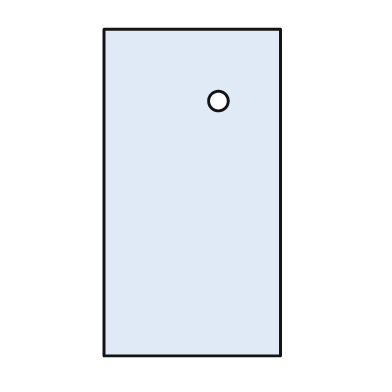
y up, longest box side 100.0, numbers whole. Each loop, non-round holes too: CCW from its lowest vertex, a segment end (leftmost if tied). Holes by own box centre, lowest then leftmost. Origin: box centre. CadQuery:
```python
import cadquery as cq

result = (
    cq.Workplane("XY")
    .moveTo(-27.0, -50.0)
    .lineTo(27.0, -50.0)
    .lineTo(27.0, 50.0)
    .lineTo(-27.0, 50.0)
    .close()
    .moveTo(8.0, 28.0)
    .circle(3.0)
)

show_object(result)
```